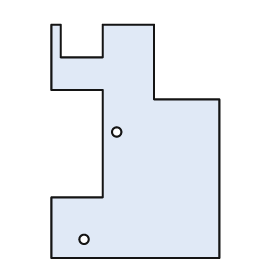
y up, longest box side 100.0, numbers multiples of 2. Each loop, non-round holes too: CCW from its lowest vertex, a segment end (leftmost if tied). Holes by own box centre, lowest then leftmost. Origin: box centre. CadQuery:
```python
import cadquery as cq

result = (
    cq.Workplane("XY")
    .moveTo(-36.0, -50.0)
    .lineTo(36.0, -50.0)
    .lineTo(36.0, 18.0)
    .lineTo(8.0, 18.0)
    .lineTo(8.0, 50.0)
    .lineTo(-14.0, 50.0)
    .lineTo(-14.0, 36.0)
    .lineTo(-32.0, 36.0)
    .lineTo(-32.0, 50.0)
    .lineTo(-36.0, 50.0)
    .lineTo(-36.0, 22.0)
    .lineTo(-14.0, 22.0)
    .lineTo(-14.0, -24.0)
    .lineTo(-36.0, -24.0)
    .close()
    .moveTo(-22.0, -42.0)
    .circle(2.0)
    .moveTo(-8.0, 4.0)
    .circle(2.0)
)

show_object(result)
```